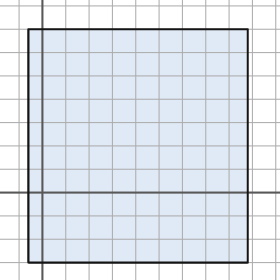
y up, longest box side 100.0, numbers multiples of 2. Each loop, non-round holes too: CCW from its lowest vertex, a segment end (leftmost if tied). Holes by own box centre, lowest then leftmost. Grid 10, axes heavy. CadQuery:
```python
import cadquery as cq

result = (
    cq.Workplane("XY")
    .moveTo(-6.0, -30.0)
    .lineTo(88.0, -30.0)
    .lineTo(88.0, 70.0)
    .lineTo(-6.0, 70.0)
    .close()
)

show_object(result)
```